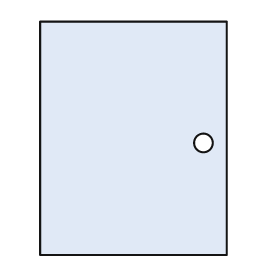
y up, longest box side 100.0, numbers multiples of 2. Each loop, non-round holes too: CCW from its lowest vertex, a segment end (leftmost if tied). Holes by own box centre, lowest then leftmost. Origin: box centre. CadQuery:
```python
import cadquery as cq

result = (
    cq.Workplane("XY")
    .moveTo(-40.0, -50.0)
    .lineTo(40.0, -50.0)
    .lineTo(40.0, 50.0)
    .lineTo(-40.0, 50.0)
    .close()
    .moveTo(30.0, -2.0)
    .circle(4.0)
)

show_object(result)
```